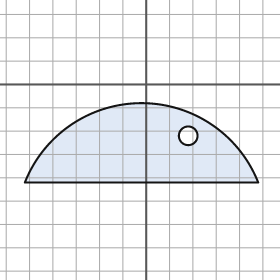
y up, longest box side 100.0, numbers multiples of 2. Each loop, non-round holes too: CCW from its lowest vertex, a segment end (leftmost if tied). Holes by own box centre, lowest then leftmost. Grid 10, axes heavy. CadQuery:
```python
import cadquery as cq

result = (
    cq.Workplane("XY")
    .moveTo(-52.0, -42.0)
    .lineTo(48.0, -42.0)
    .threePointArc((-2.0, -8.0), (-52.0, -42.0))
    .close()
    .moveTo(18.0, -22.0)
    .circle(4.0)
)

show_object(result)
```